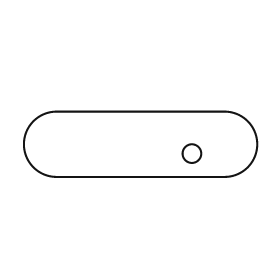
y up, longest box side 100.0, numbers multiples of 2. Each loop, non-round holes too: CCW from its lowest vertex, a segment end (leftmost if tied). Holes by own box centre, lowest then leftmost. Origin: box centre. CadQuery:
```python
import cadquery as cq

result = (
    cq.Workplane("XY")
    .moveTo(-36.0, -14.0)
    .lineTo(36.0, -14.0)
    .threePointArc((50.0, 0.0), (36.0, 14.0))
    .lineTo(-36.0, 14.0)
    .threePointArc((-50.0, 0.0), (-36.0, -14.0))
    .close()
    .moveTo(22.0, -4.0)
    .circle(4.0)
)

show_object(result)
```